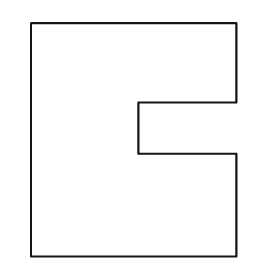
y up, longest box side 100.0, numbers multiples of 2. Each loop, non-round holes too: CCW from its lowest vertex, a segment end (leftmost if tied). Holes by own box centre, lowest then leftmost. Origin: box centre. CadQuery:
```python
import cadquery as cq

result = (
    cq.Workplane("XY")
    .moveTo(-44.0, -50.0)
    .lineTo(44.0, -50.0)
    .lineTo(44.0, -6.0)
    .lineTo(2.0, -6.0)
    .lineTo(2.0, 16.0)
    .lineTo(44.0, 16.0)
    .lineTo(44.0, 50.0)
    .lineTo(-44.0, 50.0)
    .close()
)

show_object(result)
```